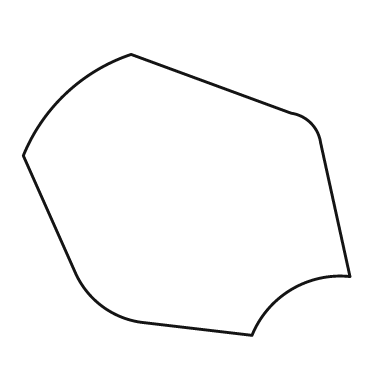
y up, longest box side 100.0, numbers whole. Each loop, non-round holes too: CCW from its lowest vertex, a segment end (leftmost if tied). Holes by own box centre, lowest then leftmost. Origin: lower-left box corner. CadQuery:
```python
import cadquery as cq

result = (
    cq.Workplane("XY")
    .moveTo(70.0, 0.0)
    .threePointArc((82.0, 14.0), (100.0, 18.0))
    .lineTo(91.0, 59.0)
    .threePointArc((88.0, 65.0), (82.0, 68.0))
    .lineTo(33.0, 86.0)
    .threePointArc((13.0, 74.0), (0.0, 55.0))
    .lineTo(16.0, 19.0)
    .threePointArc((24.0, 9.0), (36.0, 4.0))
    .close()
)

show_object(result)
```